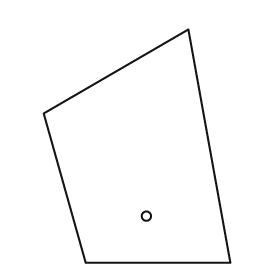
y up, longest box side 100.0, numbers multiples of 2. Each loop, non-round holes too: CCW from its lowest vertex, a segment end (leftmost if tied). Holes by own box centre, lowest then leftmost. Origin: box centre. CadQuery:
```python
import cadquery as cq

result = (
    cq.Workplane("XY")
    .moveTo(-22.0, -50.0)
    .lineTo(40.0, -50.0)
    .lineTo(22.0, 50.0)
    .lineTo(-40.0, 14.0)
    .close()
    .moveTo(4.0, -30.0)
    .circle(2.0)
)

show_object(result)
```